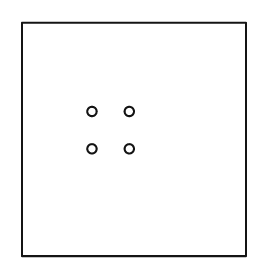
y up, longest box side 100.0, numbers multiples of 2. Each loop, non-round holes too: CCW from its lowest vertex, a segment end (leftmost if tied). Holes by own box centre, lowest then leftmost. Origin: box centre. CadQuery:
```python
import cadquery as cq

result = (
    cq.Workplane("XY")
    .moveTo(-48.0, -50.0)
    .lineTo(48.0, -50.0)
    .lineTo(48.0, 50.0)
    .lineTo(-48.0, 50.0)
    .close()
    .moveTo(-18.0, -4.0)
    .circle(2.0)
    .moveTo(-2.0, -4.0)
    .circle(2.0)
    .moveTo(-18.0, 12.0)
    .circle(2.0)
    .moveTo(-2.0, 12.0)
    .circle(2.0)
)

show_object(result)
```